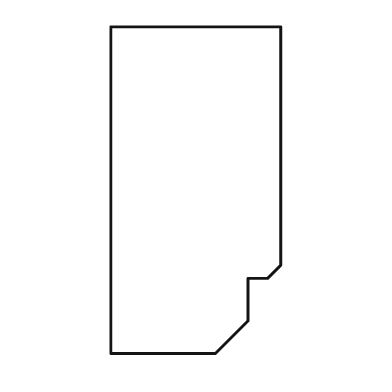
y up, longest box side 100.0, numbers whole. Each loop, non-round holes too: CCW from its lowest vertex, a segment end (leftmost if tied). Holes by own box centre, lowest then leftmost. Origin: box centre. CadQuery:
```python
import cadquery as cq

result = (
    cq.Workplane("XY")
    .moveTo(-26.0, -50.0)
    .lineTo(6.0, -50.0)
    .lineTo(16.0, -40.0)
    .lineTo(16.0, -27.0)
    .lineTo(22.0, -27.0)
    .lineTo(26.0, -23.0)
    .lineTo(26.0, 50.0)
    .lineTo(-26.0, 50.0)
    .close()
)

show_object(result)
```